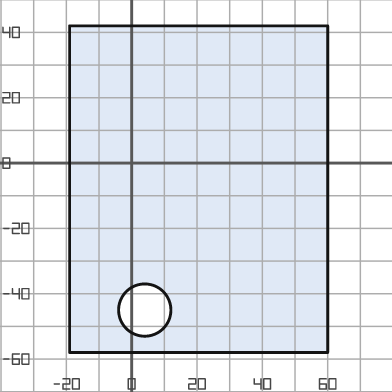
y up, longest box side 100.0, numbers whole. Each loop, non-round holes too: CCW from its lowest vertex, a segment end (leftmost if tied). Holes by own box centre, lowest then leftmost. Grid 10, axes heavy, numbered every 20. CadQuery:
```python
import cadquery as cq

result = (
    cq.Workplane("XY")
    .moveTo(-19.0, -58.0)
    .lineTo(60.0, -58.0)
    .lineTo(60.0, 42.0)
    .lineTo(-19.0, 42.0)
    .close()
    .moveTo(4.0, -45.0)
    .circle(8.0)
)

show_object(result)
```